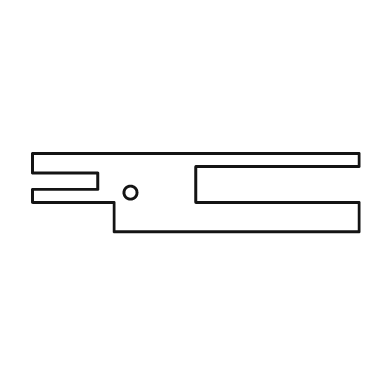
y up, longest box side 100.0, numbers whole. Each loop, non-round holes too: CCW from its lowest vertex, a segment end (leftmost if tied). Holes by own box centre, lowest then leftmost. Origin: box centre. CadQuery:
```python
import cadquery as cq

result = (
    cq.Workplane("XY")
    .moveTo(-25.0, -12.0)
    .lineTo(50.0, -12.0)
    .lineTo(50.0, -3.0)
    .lineTo(0.0, -3.0)
    .lineTo(0.0, 8.0)
    .lineTo(50.0, 8.0)
    .lineTo(50.0, 12.0)
    .lineTo(-50.0, 12.0)
    .lineTo(-50.0, 6.0)
    .lineTo(-30.0, 6.0)
    .lineTo(-30.0, 1.0)
    .lineTo(-50.0, 1.0)
    .lineTo(-50.0, -3.0)
    .lineTo(-25.0, -3.0)
    .close()
    .moveTo(-20.0, 0.0)
    .circle(2.0)
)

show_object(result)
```